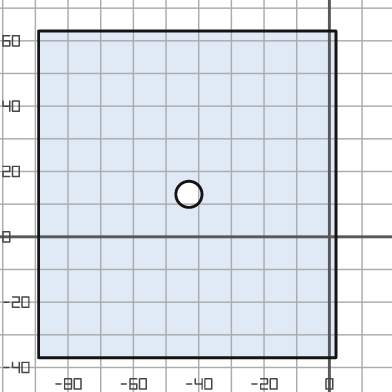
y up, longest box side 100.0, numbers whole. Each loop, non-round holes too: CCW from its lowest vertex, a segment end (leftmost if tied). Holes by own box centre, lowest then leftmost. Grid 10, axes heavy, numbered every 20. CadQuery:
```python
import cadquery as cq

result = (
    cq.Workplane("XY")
    .moveTo(-89.0, -37.0)
    .lineTo(2.0, -37.0)
    .lineTo(2.0, 63.0)
    .lineTo(-89.0, 63.0)
    .close()
    .moveTo(-43.0, 13.0)
    .circle(4.0)
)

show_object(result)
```